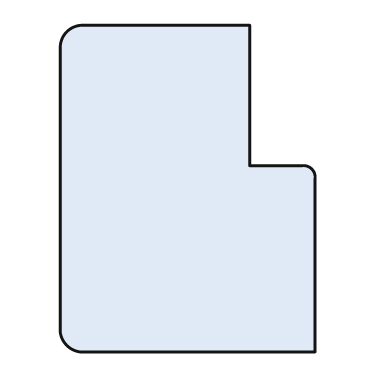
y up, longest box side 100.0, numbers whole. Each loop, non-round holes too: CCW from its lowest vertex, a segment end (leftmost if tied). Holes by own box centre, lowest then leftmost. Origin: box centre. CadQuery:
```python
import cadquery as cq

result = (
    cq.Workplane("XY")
    .moveTo(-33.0, -50.0)
    .lineTo(39.0, -50.0)
    .lineTo(39.0, 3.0)
    .threePointArc((38.0, 6.0), (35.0, 7.0))
    .lineTo(19.0, 7.0)
    .lineTo(19.0, 50.0)
    .lineTo(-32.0, 50.0)
    .threePointArc((-37.0, 48.0), (-39.0, 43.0))
    .lineTo(-39.0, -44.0)
    .threePointArc((-37.0, -48.0), (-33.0, -50.0))
    .close()
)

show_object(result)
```